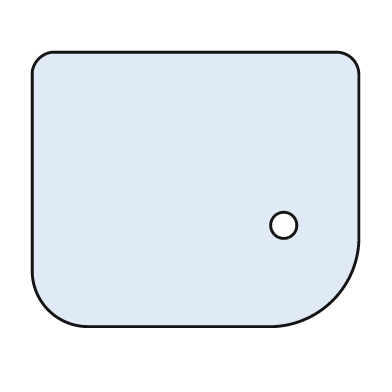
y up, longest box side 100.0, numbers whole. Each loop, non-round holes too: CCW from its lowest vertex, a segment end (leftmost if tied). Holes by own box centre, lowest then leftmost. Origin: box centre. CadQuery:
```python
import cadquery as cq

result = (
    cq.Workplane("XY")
    .moveTo(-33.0, -42.0)
    .lineTo(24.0, -42.0)
    .threePointArc((42.0, -34.0), (50.0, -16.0))
    .lineTo(50.0, 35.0)
    .threePointArc((48.0, 40.0), (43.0, 42.0))
    .lineTo(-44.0, 42.0)
    .threePointArc((-48.0, 40.0), (-50.0, 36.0))
    .lineTo(-50.0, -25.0)
    .threePointArc((-45.0, -37.0), (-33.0, -42.0))
    .close()
    .moveTo(27.0, -11.0)
    .circle(4.0)
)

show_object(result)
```